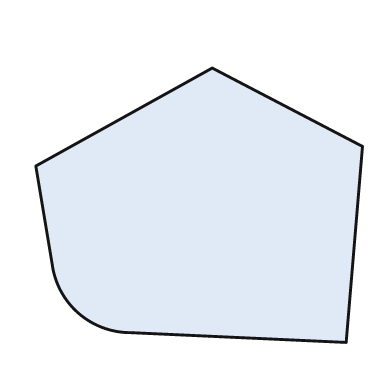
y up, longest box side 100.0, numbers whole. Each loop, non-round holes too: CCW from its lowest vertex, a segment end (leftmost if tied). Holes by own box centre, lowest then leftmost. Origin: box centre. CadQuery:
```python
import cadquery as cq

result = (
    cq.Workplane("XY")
    .moveTo(45.0, -42.0)
    .lineTo(50.0, 18.0)
    .lineTo(4.0, 42.0)
    .lineTo(-50.0, 12.0)
    .lineTo(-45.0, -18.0)
    .threePointArc((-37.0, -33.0), (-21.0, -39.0))
    .close()
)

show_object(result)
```